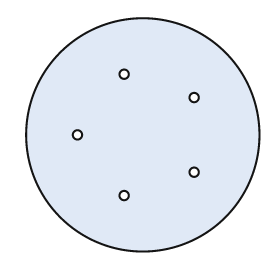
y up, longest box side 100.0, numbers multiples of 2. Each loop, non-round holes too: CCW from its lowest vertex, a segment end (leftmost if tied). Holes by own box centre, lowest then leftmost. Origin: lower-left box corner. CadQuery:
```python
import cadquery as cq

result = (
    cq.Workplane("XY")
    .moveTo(50.0, 50.0)
    .circle(50.0)
    .moveTo(42.0, 24.0)
    .circle(2.0)
    .moveTo(72.0, 34.0)
    .circle(2.0)
    .moveTo(22.0, 50.0)
    .circle(2.0)
    .moveTo(72.0, 66.0)
    .circle(2.0)
    .moveTo(42.0, 76.0)
    .circle(2.0)
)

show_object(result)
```